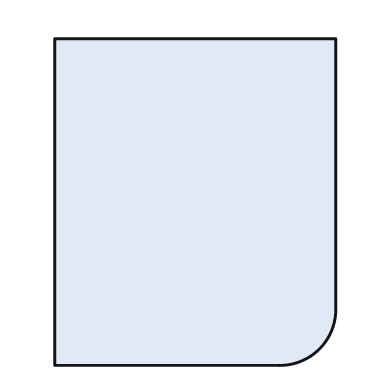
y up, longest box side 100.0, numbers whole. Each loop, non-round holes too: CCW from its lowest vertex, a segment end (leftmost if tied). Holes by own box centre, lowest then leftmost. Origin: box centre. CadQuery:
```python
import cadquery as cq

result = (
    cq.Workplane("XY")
    .moveTo(-43.0, -50.0)
    .lineTo(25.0, -50.0)
    .threePointArc((38.0, -45.0), (43.0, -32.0))
    .lineTo(43.0, 50.0)
    .lineTo(-43.0, 50.0)
    .close()
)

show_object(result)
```